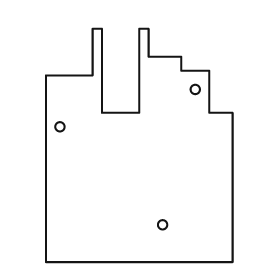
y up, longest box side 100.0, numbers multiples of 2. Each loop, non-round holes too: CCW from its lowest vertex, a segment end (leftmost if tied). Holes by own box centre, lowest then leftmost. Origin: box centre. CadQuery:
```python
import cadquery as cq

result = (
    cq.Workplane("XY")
    .moveTo(-40.0, -50.0)
    .lineTo(40.0, -50.0)
    .lineTo(40.0, 14.0)
    .lineTo(30.0, 14.0)
    .lineTo(30.0, 32.0)
    .lineTo(18.0, 32.0)
    .lineTo(18.0, 38.0)
    .lineTo(4.0, 38.0)
    .lineTo(4.0, 50.0)
    .lineTo(0.0, 50.0)
    .lineTo(0.0, 14.0)
    .lineTo(-16.0, 14.0)
    .lineTo(-16.0, 50.0)
    .lineTo(-20.0, 50.0)
    .lineTo(-20.0, 30.0)
    .lineTo(-40.0, 30.0)
    .close()
    .moveTo(10.0, -34.0)
    .circle(2.0)
    .moveTo(-34.0, 8.0)
    .circle(2.0)
    .moveTo(24.0, 24.0)
    .circle(2.0)
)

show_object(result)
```